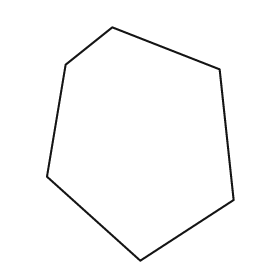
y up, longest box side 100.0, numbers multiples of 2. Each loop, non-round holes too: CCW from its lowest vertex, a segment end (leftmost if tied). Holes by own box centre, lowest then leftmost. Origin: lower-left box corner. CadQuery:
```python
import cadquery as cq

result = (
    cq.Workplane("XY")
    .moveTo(40.0, 0.0)
    .lineTo(80.0, 26.0)
    .lineTo(74.0, 82.0)
    .lineTo(28.0, 100.0)
    .lineTo(8.0, 84.0)
    .lineTo(0.0, 36.0)
    .close()
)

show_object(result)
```